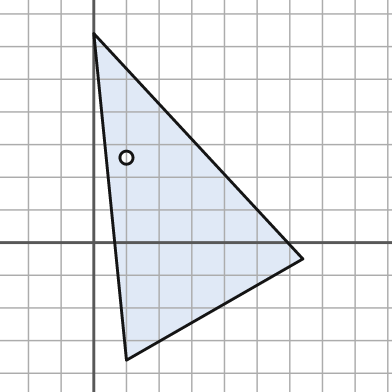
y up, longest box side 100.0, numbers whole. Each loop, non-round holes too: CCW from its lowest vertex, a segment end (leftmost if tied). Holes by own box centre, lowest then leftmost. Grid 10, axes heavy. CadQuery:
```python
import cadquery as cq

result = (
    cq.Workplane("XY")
    .moveTo(10.0, -36.0)
    .lineTo(64.0, -5.0)
    .lineTo(0.0, 64.0)
    .close()
    .moveTo(10.0, 26.0)
    .circle(2.0)
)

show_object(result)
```